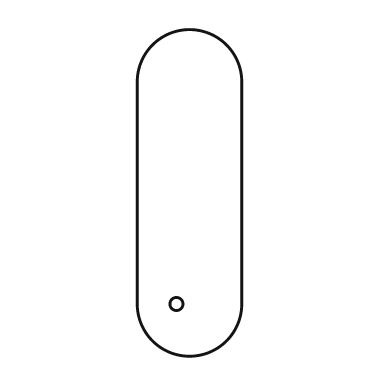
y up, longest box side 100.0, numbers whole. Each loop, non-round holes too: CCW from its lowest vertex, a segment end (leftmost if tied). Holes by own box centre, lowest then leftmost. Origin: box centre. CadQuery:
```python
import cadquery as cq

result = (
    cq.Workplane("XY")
    .moveTo(-16.0, -34.0)
    .threePointArc((0.0, -50.0), (16.0, -34.0))
    .lineTo(16.0, 34.0)
    .threePointArc((0.0, 50.0), (-16.0, 34.0))
    .close()
    .moveTo(-4.0, -34.0)
    .circle(2.0)
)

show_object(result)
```